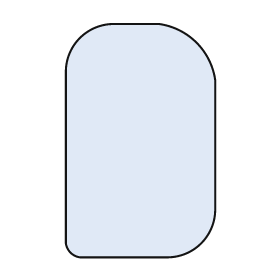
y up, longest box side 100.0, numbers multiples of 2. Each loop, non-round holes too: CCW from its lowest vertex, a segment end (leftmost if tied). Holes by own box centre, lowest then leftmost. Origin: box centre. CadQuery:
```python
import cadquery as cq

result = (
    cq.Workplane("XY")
    .moveTo(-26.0, -50.0)
    .lineTo(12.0, -50.0)
    .threePointArc((26.0, -44.0), (32.0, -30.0))
    .lineTo(32.0, 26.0)
    .threePointArc((24.0, 42.0), (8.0, 50.0))
    .lineTo(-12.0, 50.0)
    .threePointArc((-26.0, 44.0), (-32.0, 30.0))
    .lineTo(-32.0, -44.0)
    .threePointArc((-30.0, -48.0), (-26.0, -50.0))
    .close()
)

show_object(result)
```